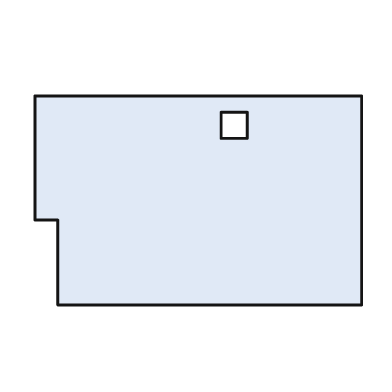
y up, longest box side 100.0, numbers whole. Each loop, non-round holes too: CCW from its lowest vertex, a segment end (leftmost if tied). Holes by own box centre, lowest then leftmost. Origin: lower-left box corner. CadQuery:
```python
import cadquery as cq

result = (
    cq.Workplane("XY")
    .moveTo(7.0, 0.0)
    .lineTo(100.0, 0.0)
    .lineTo(100.0, 64.0)
    .lineTo(0.0, 64.0)
    .lineTo(0.0, 26.0)
    .lineTo(7.0, 26.0)
    .close()
    .moveTo(57.0, 51.0)
    .lineTo(65.0, 51.0)
    .lineTo(65.0, 59.0)
    .lineTo(57.0, 59.0)
    .close()
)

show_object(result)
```